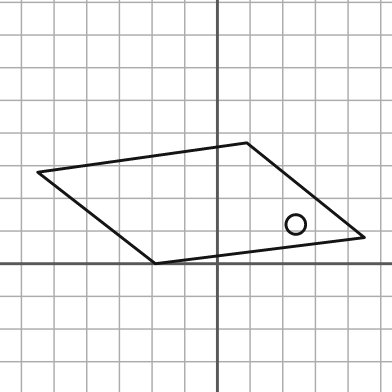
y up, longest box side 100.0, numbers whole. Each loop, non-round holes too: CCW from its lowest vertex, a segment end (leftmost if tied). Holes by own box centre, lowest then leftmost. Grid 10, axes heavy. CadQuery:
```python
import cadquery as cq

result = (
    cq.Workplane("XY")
    .moveTo(-19.0, 0.0)
    .lineTo(45.0, 8.0)
    .lineTo(9.0, 37.0)
    .lineTo(-55.0, 28.0)
    .close()
    .moveTo(24.0, 12.0)
    .circle(3.0)
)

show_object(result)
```